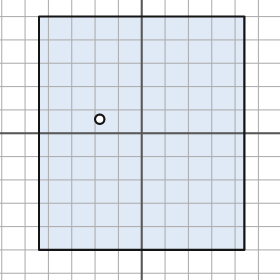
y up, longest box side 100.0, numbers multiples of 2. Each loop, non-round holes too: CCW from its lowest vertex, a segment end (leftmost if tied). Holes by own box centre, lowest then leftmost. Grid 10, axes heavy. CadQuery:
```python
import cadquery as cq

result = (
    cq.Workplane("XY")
    .moveTo(-44.0, -50.0)
    .lineTo(44.0, -50.0)
    .lineTo(44.0, 50.0)
    .lineTo(-44.0, 50.0)
    .close()
    .moveTo(-18.0, 6.0)
    .circle(2.0)
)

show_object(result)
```